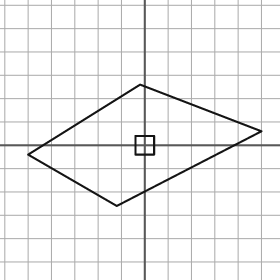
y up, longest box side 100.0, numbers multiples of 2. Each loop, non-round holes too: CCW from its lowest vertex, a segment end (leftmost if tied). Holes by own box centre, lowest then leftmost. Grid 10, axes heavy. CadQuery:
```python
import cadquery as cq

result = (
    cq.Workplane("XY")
    .moveTo(-12.0, -26.0)
    .lineTo(50.0, 6.0)
    .lineTo(-2.0, 26.0)
    .lineTo(-50.0, -4.0)
    .close()
    .moveTo(-4.0, -4.0)
    .lineTo(4.0, -4.0)
    .lineTo(4.0, 4.0)
    .lineTo(-4.0, 4.0)
    .close()
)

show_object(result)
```